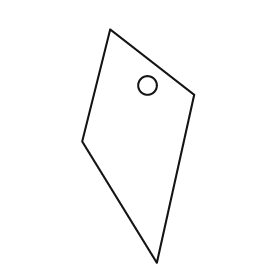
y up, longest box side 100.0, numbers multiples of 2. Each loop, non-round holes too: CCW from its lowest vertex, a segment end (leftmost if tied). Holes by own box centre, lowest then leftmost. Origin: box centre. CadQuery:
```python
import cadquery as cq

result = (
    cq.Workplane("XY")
    .moveTo(8.0, -50.0)
    .lineTo(24.0, 22.0)
    .lineTo(-12.0, 50.0)
    .lineTo(-24.0, 2.0)
    .close()
    .moveTo(4.0, 26.0)
    .circle(4.0)
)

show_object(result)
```